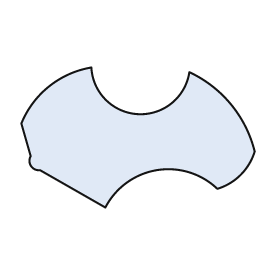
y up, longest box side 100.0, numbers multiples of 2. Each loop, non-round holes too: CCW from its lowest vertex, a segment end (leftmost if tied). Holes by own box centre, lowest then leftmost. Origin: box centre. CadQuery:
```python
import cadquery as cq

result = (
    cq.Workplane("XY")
    .moveTo(-14.0, -30.0)
    .threePointArc((8.0, -14.0), (34.0, -22.0))
    .threePointArc((44.0, -16.0), (50.0, -6.0))
    .threePointArc((40.0, 14.0), (22.0, 28.0))
    .threePointArc((0.0, 10.0), (-20.0, 30.0))
    .threePointArc((-38.0, 22.0), (-50.0, 6.0))
    .lineTo(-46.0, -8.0)
    .threePointArc((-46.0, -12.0), (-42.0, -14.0))
    .close()
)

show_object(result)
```